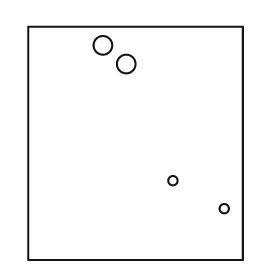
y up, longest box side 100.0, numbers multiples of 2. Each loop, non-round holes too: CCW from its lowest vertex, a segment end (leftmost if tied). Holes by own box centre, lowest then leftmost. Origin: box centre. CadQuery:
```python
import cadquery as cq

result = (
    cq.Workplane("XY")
    .moveTo(-46.0, -50.0)
    .lineTo(46.0, -50.0)
    .lineTo(46.0, 50.0)
    .lineTo(-46.0, 50.0)
    .close()
    .moveTo(38.0, -28.0)
    .circle(2.0)
    .moveTo(16.0, -16.0)
    .circle(2.0)
    .moveTo(-4.0, 34.0)
    .circle(4.0)
    .moveTo(-14.0, 42.0)
    .circle(4.0)
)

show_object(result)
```